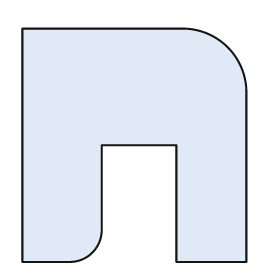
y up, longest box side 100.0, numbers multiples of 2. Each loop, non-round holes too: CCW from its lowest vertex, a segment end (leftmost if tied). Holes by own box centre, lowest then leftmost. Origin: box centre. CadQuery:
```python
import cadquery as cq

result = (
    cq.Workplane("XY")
    .moveTo(-48.0, -50.0)
    .lineTo(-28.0, -50.0)
    .threePointArc((-18.0, -46.0), (-14.0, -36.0))
    .lineTo(-14.0, 0.0)
    .lineTo(18.0, 0.0)
    .lineTo(18.0, -50.0)
    .lineTo(48.0, -50.0)
    .lineTo(48.0, 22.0)
    .threePointArc((40.0, 42.0), (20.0, 50.0))
    .lineTo(-48.0, 50.0)
    .close()
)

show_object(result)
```